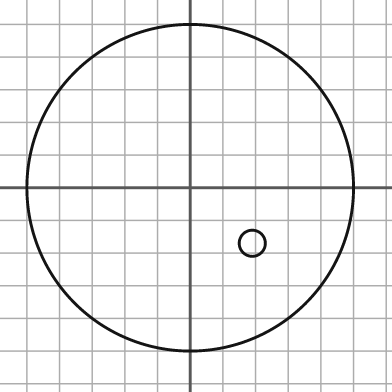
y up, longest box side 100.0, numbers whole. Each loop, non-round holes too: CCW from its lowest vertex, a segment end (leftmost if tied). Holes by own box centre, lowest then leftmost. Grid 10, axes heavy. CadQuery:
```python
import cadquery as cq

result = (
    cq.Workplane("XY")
    .moveTo(0.0, 0.0)
    .circle(50.0)
    .moveTo(19.0, -17.0)
    .circle(4.0)
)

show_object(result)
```